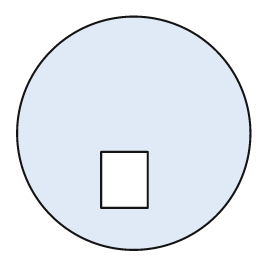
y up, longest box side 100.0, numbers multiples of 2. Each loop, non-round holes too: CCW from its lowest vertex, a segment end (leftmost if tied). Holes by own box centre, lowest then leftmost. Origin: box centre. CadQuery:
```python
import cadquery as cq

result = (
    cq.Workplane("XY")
    .moveTo(0.0, 0.0)
    .circle(50.0)
    .moveTo(-14.0, -32.0)
    .lineTo(6.0, -32.0)
    .lineTo(6.0, -8.0)
    .lineTo(-14.0, -8.0)
    .close()
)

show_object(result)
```